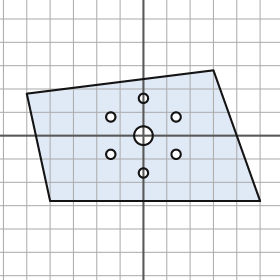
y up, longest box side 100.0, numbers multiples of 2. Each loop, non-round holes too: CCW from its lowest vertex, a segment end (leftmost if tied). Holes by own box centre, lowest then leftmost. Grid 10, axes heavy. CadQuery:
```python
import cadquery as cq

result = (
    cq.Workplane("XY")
    .moveTo(-40.0, -28.0)
    .lineTo(50.0, -28.0)
    .lineTo(30.0, 28.0)
    .lineTo(-50.0, 18.0)
    .close()
    .moveTo(0.0, -16.0)
    .circle(2.0)
    .moveTo(-14.0, -8.0)
    .circle(2.0)
    .moveTo(14.0, -8.0)
    .circle(2.0)
    .moveTo(0.0, 0.0)
    .circle(4.0)
    .moveTo(-14.0, 8.0)
    .circle(2.0)
    .moveTo(14.0, 8.0)
    .circle(2.0)
    .moveTo(0.0, 16.0)
    .circle(2.0)
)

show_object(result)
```